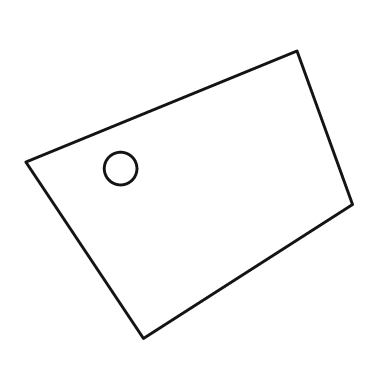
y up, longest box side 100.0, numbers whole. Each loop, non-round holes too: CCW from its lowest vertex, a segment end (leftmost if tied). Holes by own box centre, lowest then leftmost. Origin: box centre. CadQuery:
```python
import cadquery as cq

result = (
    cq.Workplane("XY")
    .moveTo(-14.0, -44.0)
    .lineTo(50.0, -3.0)
    .lineTo(33.0, 44.0)
    .lineTo(-50.0, 10.0)
    .close()
    .moveTo(-21.0, 8.0)
    .circle(5.0)
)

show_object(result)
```